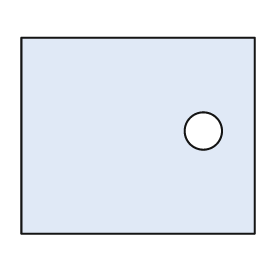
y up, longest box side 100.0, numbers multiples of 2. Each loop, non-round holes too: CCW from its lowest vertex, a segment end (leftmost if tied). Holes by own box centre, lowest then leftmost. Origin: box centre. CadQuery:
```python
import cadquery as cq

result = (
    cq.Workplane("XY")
    .moveTo(-50.0, -42.0)
    .lineTo(50.0, -42.0)
    .lineTo(50.0, 42.0)
    .lineTo(-50.0, 42.0)
    .close()
    .moveTo(28.0, 2.0)
    .circle(8.0)
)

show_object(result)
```